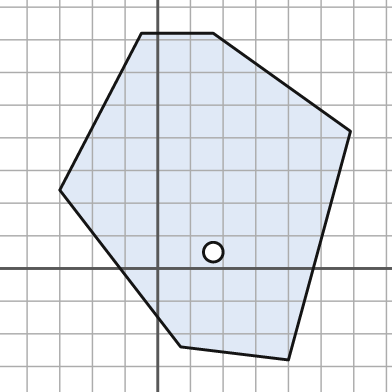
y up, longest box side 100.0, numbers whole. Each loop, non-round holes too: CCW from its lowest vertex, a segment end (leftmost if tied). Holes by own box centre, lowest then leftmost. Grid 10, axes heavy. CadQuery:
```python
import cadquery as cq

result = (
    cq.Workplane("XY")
    .moveTo(40.0, -28.0)
    .lineTo(59.0, 42.0)
    .lineTo(17.0, 72.0)
    .lineTo(-5.0, 72.0)
    .lineTo(-30.0, 24.0)
    .lineTo(7.0, -24.0)
    .close()
    .moveTo(17.0, 5.0)
    .circle(3.0)
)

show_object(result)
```